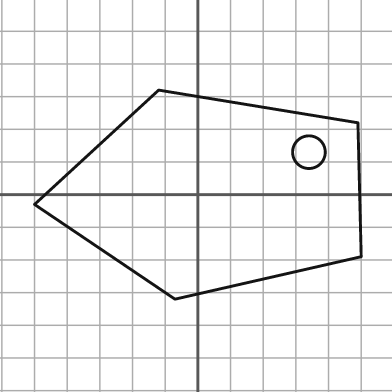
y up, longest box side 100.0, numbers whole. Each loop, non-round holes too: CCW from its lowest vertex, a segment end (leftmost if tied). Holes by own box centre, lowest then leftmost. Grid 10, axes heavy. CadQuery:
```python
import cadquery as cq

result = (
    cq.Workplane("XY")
    .moveTo(-7.0, -32.0)
    .lineTo(50.0, -19.0)
    .lineTo(49.0, 22.0)
    .lineTo(-12.0, 32.0)
    .lineTo(-50.0, -3.0)
    .close()
    .moveTo(34.0, 13.0)
    .circle(5.0)
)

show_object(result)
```